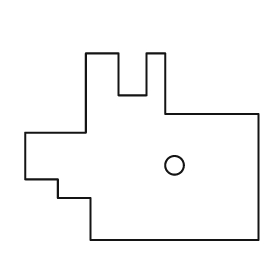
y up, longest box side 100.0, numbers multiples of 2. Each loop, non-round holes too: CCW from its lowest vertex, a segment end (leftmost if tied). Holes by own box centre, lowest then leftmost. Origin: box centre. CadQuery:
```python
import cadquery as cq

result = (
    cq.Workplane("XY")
    .moveTo(-22.0, -40.0)
    .lineTo(50.0, -40.0)
    .lineTo(50.0, 14.0)
    .lineTo(10.0, 14.0)
    .lineTo(10.0, 40.0)
    .lineTo(2.0, 40.0)
    .lineTo(2.0, 22.0)
    .lineTo(-10.0, 22.0)
    .lineTo(-10.0, 40.0)
    .lineTo(-24.0, 40.0)
    .lineTo(-24.0, 6.0)
    .lineTo(-50.0, 6.0)
    .lineTo(-50.0, -14.0)
    .lineTo(-36.0, -14.0)
    .lineTo(-36.0, -22.0)
    .lineTo(-22.0, -22.0)
    .close()
    .moveTo(14.0, -8.0)
    .circle(4.0)
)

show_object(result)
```